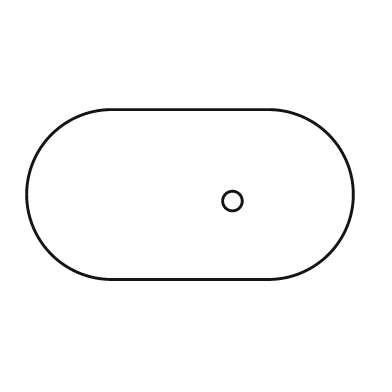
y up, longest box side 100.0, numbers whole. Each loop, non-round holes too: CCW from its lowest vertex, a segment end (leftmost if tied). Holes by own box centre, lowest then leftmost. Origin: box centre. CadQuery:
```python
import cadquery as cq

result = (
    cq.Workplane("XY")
    .moveTo(-24.0, -26.0)
    .lineTo(24.0, -26.0)
    .threePointArc((50.0, 0.0), (24.0, 26.0))
    .lineTo(-24.0, 26.0)
    .threePointArc((-50.0, 0.0), (-24.0, -26.0))
    .close()
    .moveTo(13.0, -2.0)
    .circle(3.0)
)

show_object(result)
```